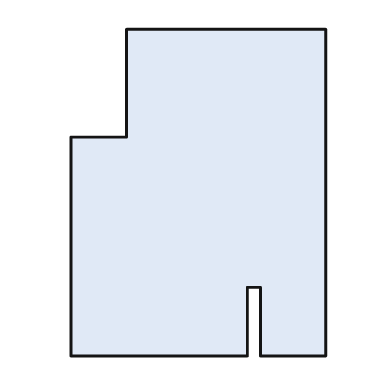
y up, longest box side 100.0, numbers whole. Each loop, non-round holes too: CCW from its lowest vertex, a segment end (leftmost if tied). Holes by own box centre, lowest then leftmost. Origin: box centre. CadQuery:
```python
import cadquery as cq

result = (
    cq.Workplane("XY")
    .moveTo(-39.0, -50.0)
    .lineTo(15.0, -50.0)
    .lineTo(15.0, -29.0)
    .lineTo(19.0, -29.0)
    .lineTo(19.0, -50.0)
    .lineTo(39.0, -50.0)
    .lineTo(39.0, 50.0)
    .lineTo(-22.0, 50.0)
    .lineTo(-22.0, 17.0)
    .lineTo(-39.0, 17.0)
    .close()
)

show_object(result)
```